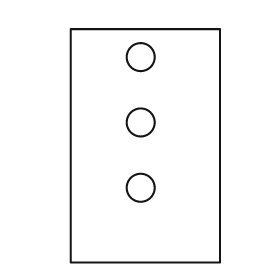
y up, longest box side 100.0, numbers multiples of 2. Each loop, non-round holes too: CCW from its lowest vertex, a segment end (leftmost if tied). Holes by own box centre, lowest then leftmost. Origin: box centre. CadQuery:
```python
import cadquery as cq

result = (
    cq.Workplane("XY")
    .moveTo(-32.0, -50.0)
    .lineTo(32.0, -50.0)
    .lineTo(32.0, 50.0)
    .lineTo(-32.0, 50.0)
    .close()
    .moveTo(-2.0, -18.0)
    .circle(6.0)
    .moveTo(-2.0, 10.0)
    .circle(6.0)
    .moveTo(-2.0, 38.0)
    .circle(6.0)
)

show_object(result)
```